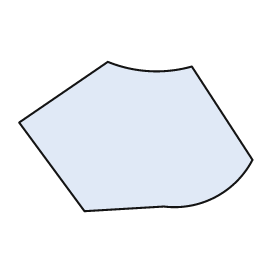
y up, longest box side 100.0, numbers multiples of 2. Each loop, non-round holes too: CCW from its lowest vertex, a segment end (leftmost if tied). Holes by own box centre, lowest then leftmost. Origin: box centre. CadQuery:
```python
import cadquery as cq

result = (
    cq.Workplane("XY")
    .moveTo(-22.0, -32.0)
    .lineTo(12.0, -30.0)
    .threePointArc((34.0, -26.0), (50.0, -10.0))
    .lineTo(24.0, 30.0)
    .threePointArc((6.0, 28.0), (-12.0, 32.0))
    .lineTo(-50.0, 6.0)
    .close()
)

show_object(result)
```